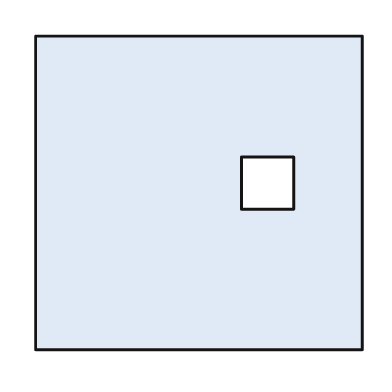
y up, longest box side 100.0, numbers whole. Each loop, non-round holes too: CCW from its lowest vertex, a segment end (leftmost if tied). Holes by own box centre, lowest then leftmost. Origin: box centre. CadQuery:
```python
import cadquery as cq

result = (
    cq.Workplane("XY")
    .moveTo(-50.0, -48.0)
    .lineTo(50.0, -48.0)
    .lineTo(50.0, 48.0)
    .lineTo(-50.0, 48.0)
    .close()
    .moveTo(13.0, -5.0)
    .lineTo(29.0, -5.0)
    .lineTo(29.0, 11.0)
    .lineTo(13.0, 11.0)
    .close()
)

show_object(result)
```